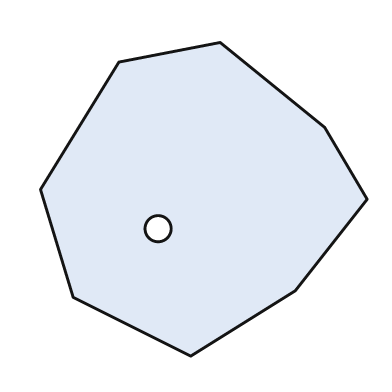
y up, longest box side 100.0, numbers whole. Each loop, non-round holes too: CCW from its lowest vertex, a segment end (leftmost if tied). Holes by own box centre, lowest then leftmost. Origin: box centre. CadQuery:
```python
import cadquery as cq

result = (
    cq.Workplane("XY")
    .moveTo(-4.0, -48.0)
    .lineTo(28.0, -28.0)
    .lineTo(50.0, 0.0)
    .lineTo(37.0, 22.0)
    .lineTo(5.0, 48.0)
    .lineTo(-26.0, 42.0)
    .lineTo(-50.0, 3.0)
    .lineTo(-40.0, -30.0)
    .close()
    .moveTo(-14.0, -9.0)
    .circle(4.0)
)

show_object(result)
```